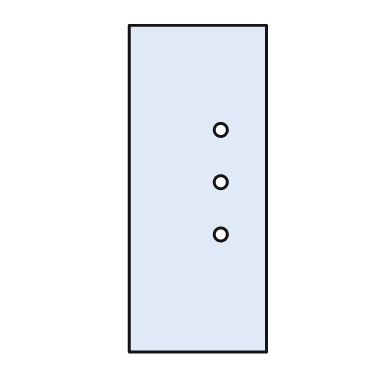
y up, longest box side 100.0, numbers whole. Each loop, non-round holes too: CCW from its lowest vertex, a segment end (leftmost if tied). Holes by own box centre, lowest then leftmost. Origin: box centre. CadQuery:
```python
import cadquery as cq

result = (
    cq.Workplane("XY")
    .moveTo(-21.0, -50.0)
    .lineTo(21.0, -50.0)
    .lineTo(21.0, 50.0)
    .lineTo(-21.0, 50.0)
    .close()
    .moveTo(7.0, -14.0)
    .circle(2.0)
    .moveTo(7.0, 2.0)
    .circle(2.0)
    .moveTo(7.0, 18.0)
    .circle(2.0)
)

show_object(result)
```